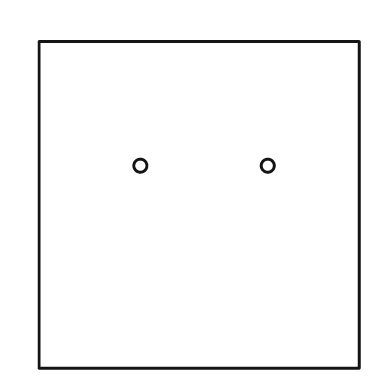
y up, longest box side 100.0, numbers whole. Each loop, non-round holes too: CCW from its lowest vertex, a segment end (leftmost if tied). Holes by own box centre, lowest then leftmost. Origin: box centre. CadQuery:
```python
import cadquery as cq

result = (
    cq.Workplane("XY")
    .moveTo(-49.0, -50.0)
    .lineTo(49.0, -50.0)
    .lineTo(49.0, 50.0)
    .lineTo(-49.0, 50.0)
    .close()
    .moveTo(-18.0, 12.0)
    .circle(2.0)
    .moveTo(21.0, 12.0)
    .circle(2.0)
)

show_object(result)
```